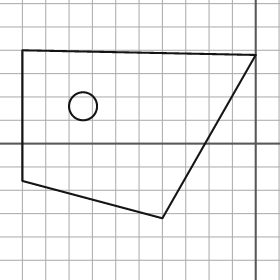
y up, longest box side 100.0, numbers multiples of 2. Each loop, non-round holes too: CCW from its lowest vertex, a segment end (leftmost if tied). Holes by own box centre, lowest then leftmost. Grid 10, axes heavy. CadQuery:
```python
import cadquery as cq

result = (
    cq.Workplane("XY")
    .moveTo(-40.0, -32.0)
    .lineTo(0.0, 38.0)
    .lineTo(-100.0, 40.0)
    .lineTo(-100.0, -16.0)
    .close()
    .moveTo(-74.0, 16.0)
    .circle(6.0)
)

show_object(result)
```